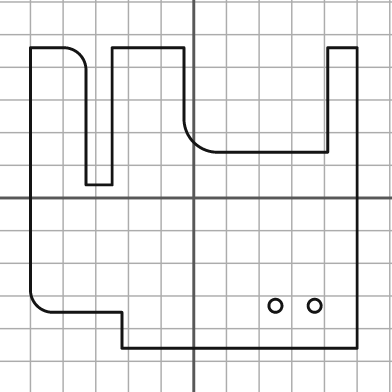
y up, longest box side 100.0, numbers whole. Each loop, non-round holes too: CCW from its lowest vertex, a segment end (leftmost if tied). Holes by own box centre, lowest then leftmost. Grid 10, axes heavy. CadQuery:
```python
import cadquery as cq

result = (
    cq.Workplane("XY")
    .moveTo(-22.0, -46.0)
    .lineTo(50.0, -46.0)
    .lineTo(50.0, 46.0)
    .lineTo(41.0, 46.0)
    .lineTo(41.0, 14.0)
    .lineTo(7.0, 14.0)
    .threePointArc((0.0, 17.0), (-3.0, 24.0))
    .lineTo(-3.0, 46.0)
    .lineTo(-25.0, 46.0)
    .lineTo(-25.0, 4.0)
    .lineTo(-33.0, 4.0)
    .lineTo(-33.0, 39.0)
    .threePointArc((-35.0, 44.0), (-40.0, 46.0))
    .lineTo(-50.0, 46.0)
    .lineTo(-50.0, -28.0)
    .threePointArc((-48.0, -33.0), (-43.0, -35.0))
    .lineTo(-22.0, -35.0)
    .close()
    .moveTo(25.0, -33.0)
    .circle(2.0)
    .moveTo(37.0, -33.0)
    .circle(2.0)
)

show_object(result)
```